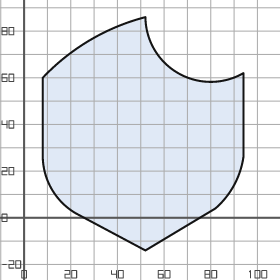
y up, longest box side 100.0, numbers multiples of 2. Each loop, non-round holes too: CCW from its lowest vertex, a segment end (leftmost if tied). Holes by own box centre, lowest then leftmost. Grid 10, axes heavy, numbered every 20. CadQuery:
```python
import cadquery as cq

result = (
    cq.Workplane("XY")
    .moveTo(52.0, -14.0)
    .lineTo(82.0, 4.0)
    .threePointArc((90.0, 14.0), (94.0, 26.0))
    .lineTo(94.0, 62.0)
    .threePointArc((66.0, 62.0), (52.0, 86.0))
    .threePointArc((28.0, 76.0), (8.0, 60.0))
    .lineTo(8.0, 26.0)
    .threePointArc((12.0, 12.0), (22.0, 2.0))
    .close()
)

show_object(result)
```